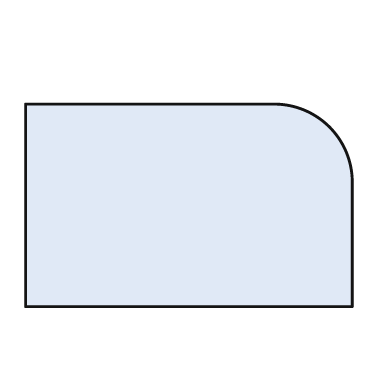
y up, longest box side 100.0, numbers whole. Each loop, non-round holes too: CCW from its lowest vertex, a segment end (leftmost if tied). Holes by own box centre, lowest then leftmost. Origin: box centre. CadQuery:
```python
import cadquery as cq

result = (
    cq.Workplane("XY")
    .moveTo(-50.0, -31.0)
    .lineTo(50.0, -31.0)
    .lineTo(50.0, 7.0)
    .threePointArc((43.0, 24.0), (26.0, 31.0))
    .lineTo(-50.0, 31.0)
    .close()
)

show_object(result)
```